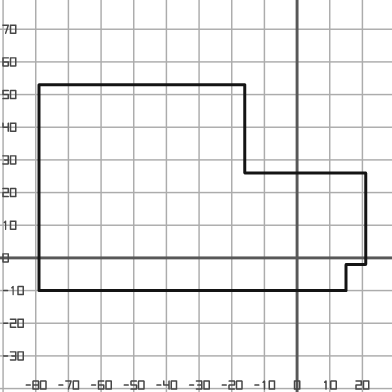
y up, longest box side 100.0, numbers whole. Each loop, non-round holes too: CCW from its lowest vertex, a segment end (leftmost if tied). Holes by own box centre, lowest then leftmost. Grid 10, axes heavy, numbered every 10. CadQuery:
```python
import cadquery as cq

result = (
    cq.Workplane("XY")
    .moveTo(-79.0, -10.0)
    .lineTo(15.0, -10.0)
    .lineTo(15.0, -2.0)
    .lineTo(21.0, -2.0)
    .lineTo(21.0, 26.0)
    .lineTo(-16.0, 26.0)
    .lineTo(-16.0, 53.0)
    .lineTo(-79.0, 53.0)
    .close()
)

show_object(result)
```